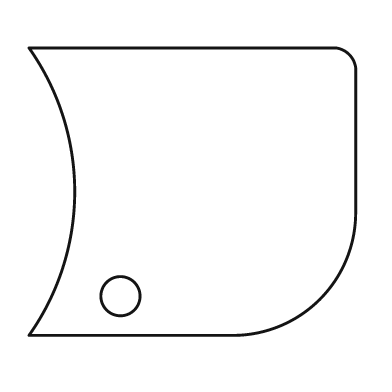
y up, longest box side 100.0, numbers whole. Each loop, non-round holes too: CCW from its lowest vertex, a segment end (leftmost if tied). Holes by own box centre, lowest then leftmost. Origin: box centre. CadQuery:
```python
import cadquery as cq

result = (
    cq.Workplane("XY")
    .moveTo(-50.0, -44.0)
    .lineTo(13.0, -44.0)
    .threePointArc((39.0, -33.0), (50.0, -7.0))
    .lineTo(50.0, 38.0)
    .threePointArc((48.0, 42.0), (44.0, 44.0))
    .lineTo(-50.0, 44.0)
    .threePointArc((-36.0, 0.0), (-50.0, -44.0))
    .close()
    .moveTo(-22.0, -32.0)
    .circle(6.0)
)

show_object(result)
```